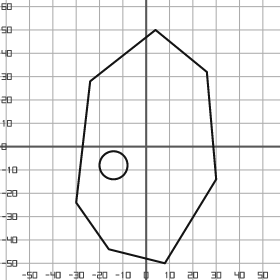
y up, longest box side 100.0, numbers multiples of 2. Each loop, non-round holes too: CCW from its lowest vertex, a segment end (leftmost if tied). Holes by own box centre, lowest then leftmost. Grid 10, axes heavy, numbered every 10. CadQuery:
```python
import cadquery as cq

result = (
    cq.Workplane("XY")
    .moveTo(8.0, -50.0)
    .lineTo(30.0, -14.0)
    .lineTo(26.0, 32.0)
    .lineTo(4.0, 50.0)
    .lineTo(-24.0, 28.0)
    .lineTo(-30.0, -24.0)
    .lineTo(-16.0, -44.0)
    .close()
    .moveTo(-14.0, -8.0)
    .circle(6.0)
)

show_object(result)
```